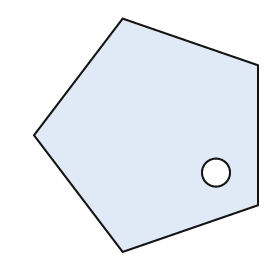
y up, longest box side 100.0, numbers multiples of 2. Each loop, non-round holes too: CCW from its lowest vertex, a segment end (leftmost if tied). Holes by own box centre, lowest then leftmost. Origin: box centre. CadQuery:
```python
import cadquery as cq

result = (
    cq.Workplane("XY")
    .moveTo(-10.0, -50.0)
    .lineTo(48.0, -30.0)
    .lineTo(48.0, 30.0)
    .lineTo(-10.0, 50.0)
    .lineTo(-48.0, 0.0)
    .close()
    .moveTo(30.0, -16.0)
    .circle(6.0)
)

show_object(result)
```